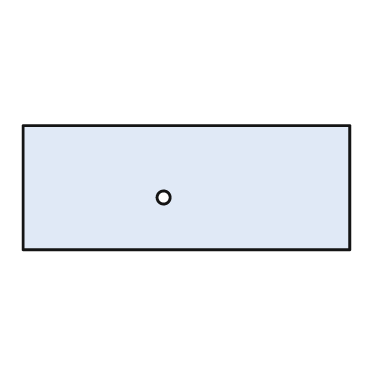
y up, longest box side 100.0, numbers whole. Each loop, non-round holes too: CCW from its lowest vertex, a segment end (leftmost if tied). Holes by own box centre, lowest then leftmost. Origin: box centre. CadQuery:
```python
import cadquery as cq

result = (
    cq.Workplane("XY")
    .moveTo(-50.0, -19.0)
    .lineTo(50.0, -19.0)
    .lineTo(50.0, 19.0)
    .lineTo(-50.0, 19.0)
    .close()
    .moveTo(-7.0, -3.0)
    .circle(2.0)
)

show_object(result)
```